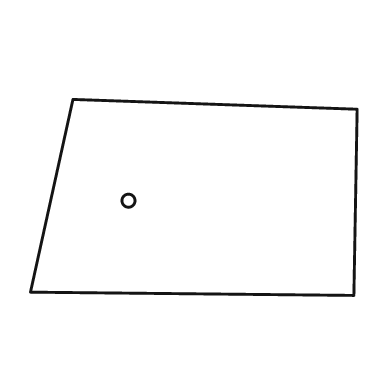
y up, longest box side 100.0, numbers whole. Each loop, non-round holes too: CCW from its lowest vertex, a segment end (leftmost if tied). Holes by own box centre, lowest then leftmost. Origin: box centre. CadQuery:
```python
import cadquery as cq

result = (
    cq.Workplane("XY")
    .moveTo(49.0, -30.0)
    .lineTo(50.0, 27.0)
    .lineTo(-37.0, 30.0)
    .lineTo(-50.0, -29.0)
    .close()
    .moveTo(-20.0, -1.0)
    .circle(2.0)
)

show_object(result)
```